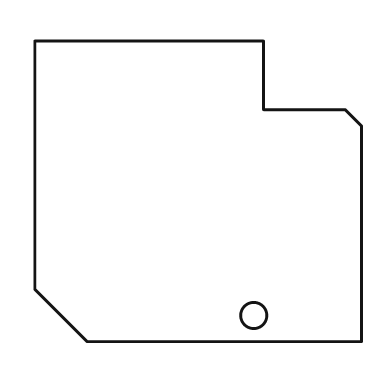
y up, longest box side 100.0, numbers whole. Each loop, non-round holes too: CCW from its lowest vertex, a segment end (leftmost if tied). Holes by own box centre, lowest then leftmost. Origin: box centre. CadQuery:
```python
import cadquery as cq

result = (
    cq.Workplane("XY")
    .moveTo(-34.0, -46.0)
    .lineTo(50.0, -46.0)
    .lineTo(50.0, 20.0)
    .lineTo(45.0, 25.0)
    .lineTo(20.0, 25.0)
    .lineTo(20.0, 46.0)
    .lineTo(-50.0, 46.0)
    .lineTo(-50.0, -30.0)
    .close()
    .moveTo(17.0, -38.0)
    .circle(4.0)
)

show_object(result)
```